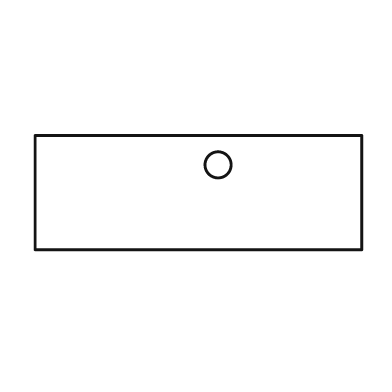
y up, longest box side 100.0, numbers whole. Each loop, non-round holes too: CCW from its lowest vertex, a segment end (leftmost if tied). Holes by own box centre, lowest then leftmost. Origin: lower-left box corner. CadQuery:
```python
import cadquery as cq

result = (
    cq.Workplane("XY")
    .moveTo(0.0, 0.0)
    .lineTo(100.0, 0.0)
    .lineTo(100.0, 35.0)
    .lineTo(0.0, 35.0)
    .close()
    .moveTo(56.0, 26.0)
    .circle(4.0)
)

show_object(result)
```